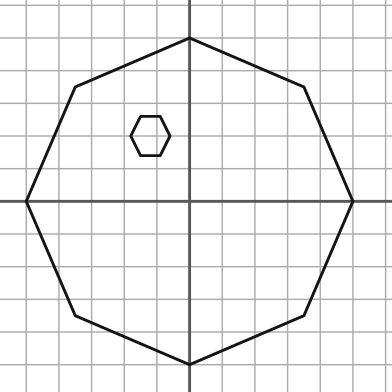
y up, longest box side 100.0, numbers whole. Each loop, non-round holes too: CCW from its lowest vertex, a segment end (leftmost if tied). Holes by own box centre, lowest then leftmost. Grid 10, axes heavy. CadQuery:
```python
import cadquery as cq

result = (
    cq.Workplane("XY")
    .moveTo(0.0, -50.0)
    .lineTo(35.0, -35.0)
    .lineTo(50.0, 0.0)
    .lineTo(35.0, 35.0)
    .lineTo(0.0, 50.0)
    .lineTo(-35.0, 35.0)
    .lineTo(-50.0, 0.0)
    .lineTo(-35.0, -35.0)
    .close()
    .moveTo(-15.0, 14.0)
    .lineTo(-9.0, 14.0)
    .lineTo(-6.0, 20.0)
    .lineTo(-9.0, 26.0)
    .lineTo(-15.0, 26.0)
    .lineTo(-18.0, 20.0)
    .close()
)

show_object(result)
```